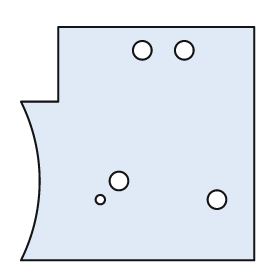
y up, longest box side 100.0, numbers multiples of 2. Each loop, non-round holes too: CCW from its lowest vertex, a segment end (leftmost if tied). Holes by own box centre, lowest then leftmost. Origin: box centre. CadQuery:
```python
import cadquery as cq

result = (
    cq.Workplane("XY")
    .moveTo(-50.0, -50.0)
    .lineTo(50.0, -50.0)
    .lineTo(50.0, 50.0)
    .lineTo(-34.0, 50.0)
    .lineTo(-34.0, 18.0)
    .lineTo(-50.0, 18.0)
    .threePointArc((-42.0, -16.0), (-50.0, -50.0))
    .close()
    .moveTo(-16.0, -24.0)
    .circle(2.0)
    .moveTo(34.0, -24.0)
    .circle(4.0)
    .moveTo(-8.0, -16.0)
    .circle(4.0)
    .moveTo(2.0, 40.0)
    .circle(4.0)
    .moveTo(20.0, 40.0)
    .circle(4.0)
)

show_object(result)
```